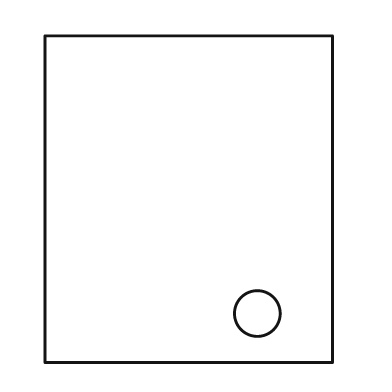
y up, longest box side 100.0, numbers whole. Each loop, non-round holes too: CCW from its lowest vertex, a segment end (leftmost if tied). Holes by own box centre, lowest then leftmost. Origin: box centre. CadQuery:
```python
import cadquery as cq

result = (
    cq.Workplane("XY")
    .moveTo(-44.0, -50.0)
    .lineTo(44.0, -50.0)
    .lineTo(44.0, 50.0)
    .lineTo(-44.0, 50.0)
    .close()
    .moveTo(21.0, -35.0)
    .circle(7.0)
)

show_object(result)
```